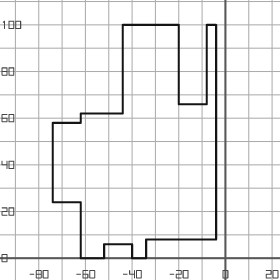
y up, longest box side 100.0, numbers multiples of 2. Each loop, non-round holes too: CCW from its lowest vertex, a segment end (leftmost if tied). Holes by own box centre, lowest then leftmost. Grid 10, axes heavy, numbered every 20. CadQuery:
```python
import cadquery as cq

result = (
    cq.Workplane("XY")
    .moveTo(-62.0, 0.0)
    .lineTo(-52.0, 0.0)
    .lineTo(-52.0, 6.0)
    .lineTo(-40.0, 6.0)
    .lineTo(-40.0, 0.0)
    .lineTo(-34.0, 0.0)
    .lineTo(-34.0, 8.0)
    .lineTo(-4.0, 8.0)
    .lineTo(-4.0, 100.0)
    .lineTo(-8.0, 100.0)
    .lineTo(-8.0, 66.0)
    .lineTo(-20.0, 66.0)
    .lineTo(-20.0, 100.0)
    .lineTo(-44.0, 100.0)
    .lineTo(-44.0, 62.0)
    .lineTo(-62.0, 62.0)
    .lineTo(-62.0, 58.0)
    .lineTo(-74.0, 58.0)
    .lineTo(-74.0, 24.0)
    .lineTo(-62.0, 24.0)
    .close()
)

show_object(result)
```